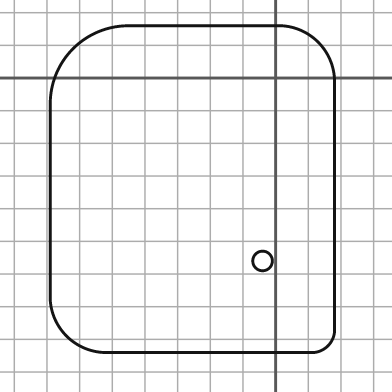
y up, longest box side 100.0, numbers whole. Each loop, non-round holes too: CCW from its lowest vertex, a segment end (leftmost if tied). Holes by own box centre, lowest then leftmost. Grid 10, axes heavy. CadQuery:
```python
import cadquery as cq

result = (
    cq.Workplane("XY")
    .moveTo(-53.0, -84.0)
    .lineTo(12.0, -84.0)
    .threePointArc((16.0, -82.0), (18.0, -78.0))
    .lineTo(18.0, 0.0)
    .threePointArc((13.0, 11.0), (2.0, 16.0))
    .lineTo(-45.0, 16.0)
    .threePointArc((-62.0, 9.0), (-69.0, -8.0))
    .lineTo(-69.0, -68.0)
    .threePointArc((-64.0, -79.0), (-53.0, -84.0))
    .close()
    .moveTo(-4.0, -56.0)
    .circle(3.0)
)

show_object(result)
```